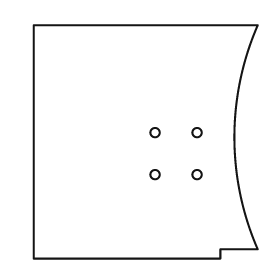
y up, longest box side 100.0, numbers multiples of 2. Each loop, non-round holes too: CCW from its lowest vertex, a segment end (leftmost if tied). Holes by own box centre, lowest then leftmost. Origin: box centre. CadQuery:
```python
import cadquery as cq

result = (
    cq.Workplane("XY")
    .moveTo(-48.0, -50.0)
    .lineTo(32.0, -50.0)
    .lineTo(32.0, -46.0)
    .lineTo(48.0, -46.0)
    .threePointArc((38.0, 2.0), (48.0, 50.0))
    .lineTo(-48.0, 50.0)
    .close()
    .moveTo(4.0, -14.0)
    .circle(2.0)
    .moveTo(22.0, -14.0)
    .circle(2.0)
    .moveTo(4.0, 4.0)
    .circle(2.0)
    .moveTo(22.0, 4.0)
    .circle(2.0)
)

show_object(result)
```